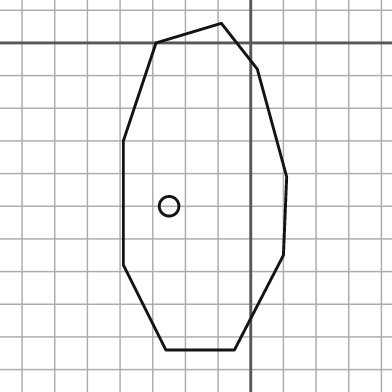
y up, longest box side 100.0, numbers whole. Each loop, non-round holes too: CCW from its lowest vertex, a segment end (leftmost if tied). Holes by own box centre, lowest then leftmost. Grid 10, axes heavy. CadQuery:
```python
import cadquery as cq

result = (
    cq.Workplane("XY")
    .moveTo(-26.0, -94.0)
    .lineTo(-5.0, -94.0)
    .lineTo(10.0, -65.0)
    .lineTo(11.0, -41.0)
    .lineTo(2.0, -8.0)
    .lineTo(-9.0, 6.0)
    .lineTo(-29.0, 0.0)
    .lineTo(-39.0, -30.0)
    .lineTo(-39.0, -68.0)
    .close()
    .moveTo(-25.0, -50.0)
    .circle(3.0)
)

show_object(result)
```